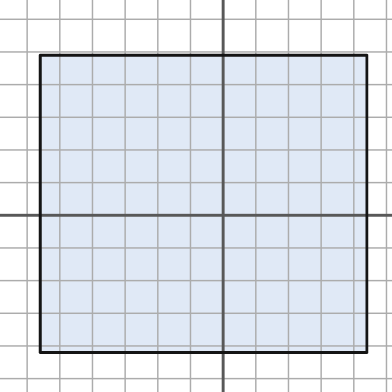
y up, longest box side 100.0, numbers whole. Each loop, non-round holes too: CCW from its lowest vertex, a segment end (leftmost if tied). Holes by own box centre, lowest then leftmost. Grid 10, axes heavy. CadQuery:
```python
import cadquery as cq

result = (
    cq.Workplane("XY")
    .moveTo(-56.0, -42.0)
    .lineTo(44.0, -42.0)
    .lineTo(44.0, 49.0)
    .lineTo(-56.0, 49.0)
    .close()
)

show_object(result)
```